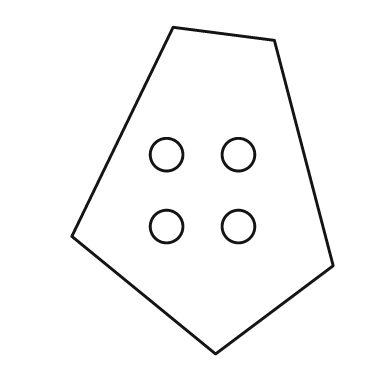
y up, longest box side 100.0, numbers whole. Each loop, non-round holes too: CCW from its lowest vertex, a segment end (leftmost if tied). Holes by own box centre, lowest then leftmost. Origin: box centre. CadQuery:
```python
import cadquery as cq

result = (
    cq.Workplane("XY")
    .moveTo(4.0, -50.0)
    .lineTo(40.0, -23.0)
    .lineTo(22.0, 46.0)
    .lineTo(-9.0, 50.0)
    .lineTo(-40.0, -14.0)
    .close()
    .moveTo(-11.0, -11.0)
    .circle(5.0)
    .moveTo(11.0, -11.0)
    .circle(5.0)
    .moveTo(-11.0, 11.0)
    .circle(5.0)
    .moveTo(11.0, 11.0)
    .circle(5.0)
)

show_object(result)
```